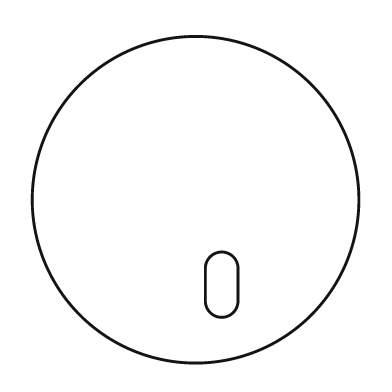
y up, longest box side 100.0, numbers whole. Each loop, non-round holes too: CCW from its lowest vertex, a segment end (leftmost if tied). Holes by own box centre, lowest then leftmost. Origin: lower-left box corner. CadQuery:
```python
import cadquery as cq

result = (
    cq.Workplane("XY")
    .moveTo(50.0, 50.0)
    .circle(50.0)
    .moveTo(53.0, 19.0)
    .threePointArc((58.0, 14.0), (63.0, 19.0))
    .lineTo(63.0, 29.0)
    .threePointArc((58.0, 34.0), (53.0, 29.0))
    .close()
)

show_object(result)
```